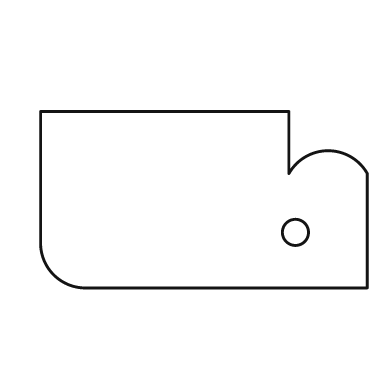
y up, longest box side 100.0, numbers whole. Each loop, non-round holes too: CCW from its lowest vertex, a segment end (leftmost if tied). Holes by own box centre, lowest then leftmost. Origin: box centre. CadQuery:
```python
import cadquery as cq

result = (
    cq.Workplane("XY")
    .moveTo(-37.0, -27.0)
    .lineTo(50.0, -27.0)
    .lineTo(50.0, 8.0)
    .threePointArc((38.0, 15.0), (26.0, 8.0))
    .lineTo(26.0, 27.0)
    .lineTo(-50.0, 27.0)
    .lineTo(-50.0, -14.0)
    .threePointArc((-46.0, -23.0), (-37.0, -27.0))
    .close()
    .moveTo(28.0, -10.0)
    .circle(4.0)
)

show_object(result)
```